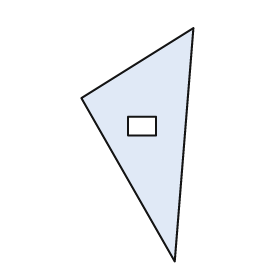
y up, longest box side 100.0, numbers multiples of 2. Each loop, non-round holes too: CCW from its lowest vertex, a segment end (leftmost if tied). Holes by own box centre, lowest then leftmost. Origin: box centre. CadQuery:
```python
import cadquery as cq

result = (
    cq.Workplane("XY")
    .moveTo(16.0, -50.0)
    .lineTo(24.0, 50.0)
    .lineTo(-24.0, 20.0)
    .close()
    .moveTo(-4.0, 4.0)
    .lineTo(8.0, 4.0)
    .lineTo(8.0, 12.0)
    .lineTo(-4.0, 12.0)
    .close()
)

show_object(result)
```